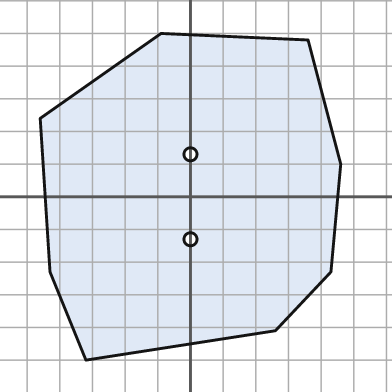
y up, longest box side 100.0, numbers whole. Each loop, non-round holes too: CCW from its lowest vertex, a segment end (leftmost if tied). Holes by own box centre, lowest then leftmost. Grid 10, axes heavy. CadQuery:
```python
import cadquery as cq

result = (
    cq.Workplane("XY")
    .moveTo(-32.0, -50.0)
    .lineTo(26.0, -41.0)
    .lineTo(43.0, -23.0)
    .lineTo(46.0, 10.0)
    .lineTo(36.0, 48.0)
    .lineTo(-9.0, 50.0)
    .lineTo(-46.0, 24.0)
    .lineTo(-43.0, -23.0)
    .close()
    .moveTo(0.0, -13.0)
    .circle(2.0)
    .moveTo(0.0, 13.0)
    .circle(2.0)
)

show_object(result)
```